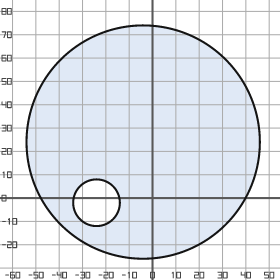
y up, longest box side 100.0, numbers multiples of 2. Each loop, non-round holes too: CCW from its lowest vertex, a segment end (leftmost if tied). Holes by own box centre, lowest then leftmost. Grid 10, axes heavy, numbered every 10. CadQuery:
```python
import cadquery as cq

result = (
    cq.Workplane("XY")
    .moveTo(-4.0, 24.0)
    .circle(50.0)
    .moveTo(-24.0, -2.0)
    .circle(10.0)
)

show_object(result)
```